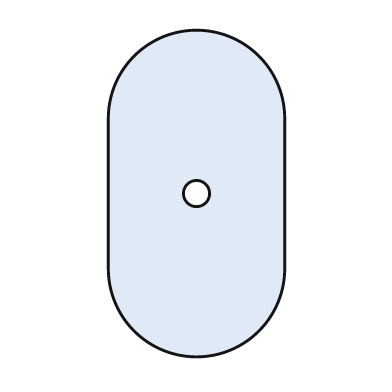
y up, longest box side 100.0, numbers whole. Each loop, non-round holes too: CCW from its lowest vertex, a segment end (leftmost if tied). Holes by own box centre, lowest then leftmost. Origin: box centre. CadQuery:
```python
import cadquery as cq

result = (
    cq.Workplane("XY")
    .moveTo(-27.0, -23.0)
    .threePointArc((0.0, -50.0), (27.0, -23.0))
    .lineTo(27.0, 23.0)
    .threePointArc((0.0, 50.0), (-27.0, 23.0))
    .close()
    .moveTo(0.0, 0.0)
    .circle(4.0)
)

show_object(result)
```